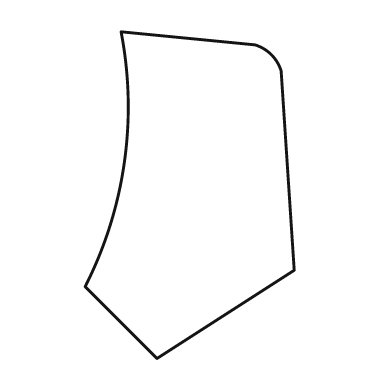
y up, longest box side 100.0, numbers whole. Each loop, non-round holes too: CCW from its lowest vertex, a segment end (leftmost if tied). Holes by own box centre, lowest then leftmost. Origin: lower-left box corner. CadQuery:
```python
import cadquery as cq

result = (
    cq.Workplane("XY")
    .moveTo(22.0, 0.0)
    .lineTo(64.0, 27.0)
    .lineTo(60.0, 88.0)
    .threePointArc((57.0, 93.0), (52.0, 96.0))
    .lineTo(11.0, 100.0)
    .threePointArc((12.0, 60.0), (0.0, 22.0))
    .close()
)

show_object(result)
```